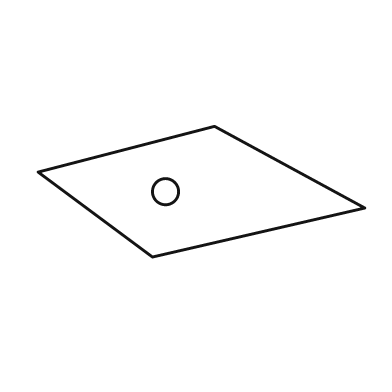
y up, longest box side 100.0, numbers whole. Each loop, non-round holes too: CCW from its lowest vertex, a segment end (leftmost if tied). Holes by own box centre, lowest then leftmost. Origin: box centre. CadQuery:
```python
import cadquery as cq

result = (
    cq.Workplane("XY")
    .moveTo(-15.0, -20.0)
    .lineTo(50.0, -5.0)
    .lineTo(4.0, 20.0)
    .lineTo(-50.0, 6.0)
    .close()
    .moveTo(-11.0, 0.0)
    .circle(4.0)
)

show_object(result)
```